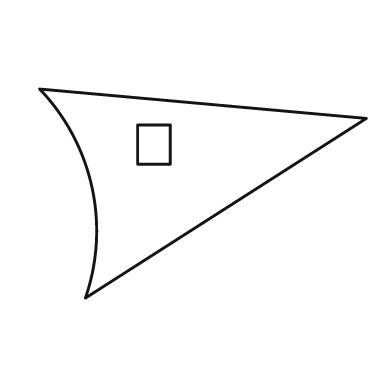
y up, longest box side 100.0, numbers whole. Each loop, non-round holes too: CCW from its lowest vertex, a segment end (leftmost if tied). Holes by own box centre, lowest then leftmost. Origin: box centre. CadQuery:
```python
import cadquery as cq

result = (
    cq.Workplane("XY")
    .moveTo(-36.0, -32.0)
    .lineTo(50.0, 23.0)
    .lineTo(-50.0, 32.0)
    .threePointArc((-34.0, 2.0), (-36.0, -32.0))
    .close()
    .moveTo(-20.0, 9.0)
    .lineTo(-10.0, 9.0)
    .lineTo(-10.0, 21.0)
    .lineTo(-20.0, 21.0)
    .close()
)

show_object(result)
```